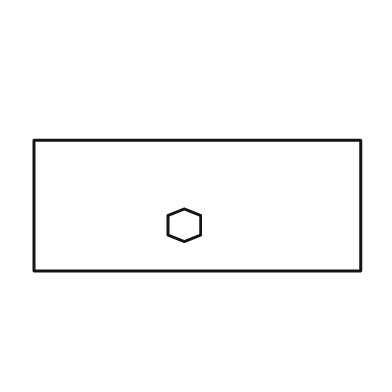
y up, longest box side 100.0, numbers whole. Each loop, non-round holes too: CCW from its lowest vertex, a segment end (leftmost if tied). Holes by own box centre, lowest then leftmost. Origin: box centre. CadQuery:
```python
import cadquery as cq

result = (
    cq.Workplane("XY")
    .moveTo(-50.0, -20.0)
    .lineTo(50.0, -20.0)
    .lineTo(50.0, 20.0)
    .lineTo(-50.0, 20.0)
    .close()
    .moveTo(-4.0, -11.0)
    .lineTo(1.0, -9.0)
    .lineTo(1.0, -3.0)
    .lineTo(-4.0, -1.0)
    .lineTo(-9.0, -3.0)
    .lineTo(-9.0, -9.0)
    .close()
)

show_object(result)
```